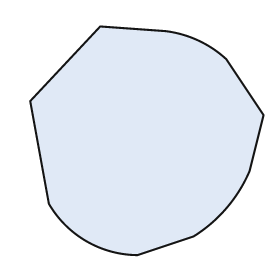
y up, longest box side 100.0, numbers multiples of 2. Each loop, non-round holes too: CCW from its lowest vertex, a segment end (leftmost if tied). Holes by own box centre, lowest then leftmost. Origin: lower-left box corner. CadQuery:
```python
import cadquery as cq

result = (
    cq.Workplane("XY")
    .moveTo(46.0, 0.0)
    .lineTo(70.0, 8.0)
    .threePointArc((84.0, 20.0), (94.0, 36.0))
    .lineTo(100.0, 60.0)
    .lineTo(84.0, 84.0)
    .threePointArc((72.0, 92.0), (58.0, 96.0))
    .lineTo(30.0, 98.0)
    .lineTo(0.0, 66.0)
    .lineTo(8.0, 22.0)
    .threePointArc((24.0, 6.0), (46.0, 0.0))
    .close()
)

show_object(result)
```